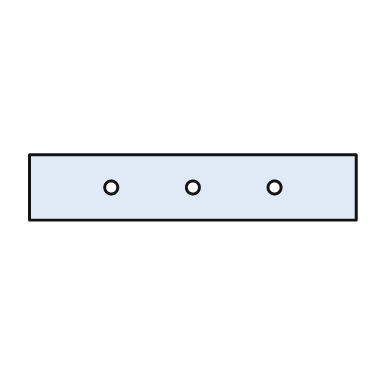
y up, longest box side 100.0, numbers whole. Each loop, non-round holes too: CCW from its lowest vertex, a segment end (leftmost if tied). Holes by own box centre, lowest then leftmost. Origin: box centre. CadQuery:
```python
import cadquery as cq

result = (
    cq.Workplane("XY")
    .moveTo(-50.0, -10.0)
    .lineTo(50.0, -10.0)
    .lineTo(50.0, 10.0)
    .lineTo(-50.0, 10.0)
    .close()
    .moveTo(-25.0, 0.0)
    .circle(2.0)
    .moveTo(0.0, 0.0)
    .circle(2.0)
    .moveTo(25.0, 0.0)
    .circle(2.0)
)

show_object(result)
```